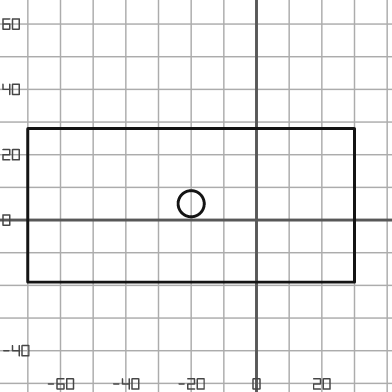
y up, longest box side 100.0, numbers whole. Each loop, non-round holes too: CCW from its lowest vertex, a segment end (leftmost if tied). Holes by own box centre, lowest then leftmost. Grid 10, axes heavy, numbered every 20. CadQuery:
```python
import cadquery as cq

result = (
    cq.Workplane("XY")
    .moveTo(-70.0, -19.0)
    .lineTo(30.0, -19.0)
    .lineTo(30.0, 28.0)
    .lineTo(-70.0, 28.0)
    .close()
    .moveTo(-20.0, 5.0)
    .circle(4.0)
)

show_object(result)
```